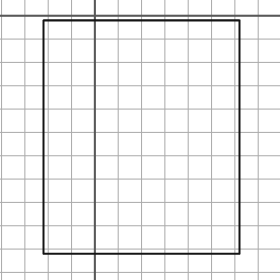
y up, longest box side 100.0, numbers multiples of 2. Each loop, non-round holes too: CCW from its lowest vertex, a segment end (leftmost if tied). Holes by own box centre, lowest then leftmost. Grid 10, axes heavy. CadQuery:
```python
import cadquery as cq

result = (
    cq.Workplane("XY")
    .moveTo(-22.0, -102.0)
    .lineTo(62.0, -102.0)
    .lineTo(62.0, -2.0)
    .lineTo(-22.0, -2.0)
    .close()
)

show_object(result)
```